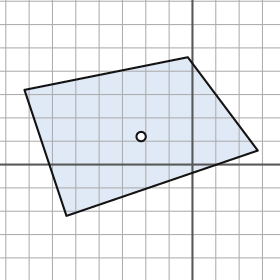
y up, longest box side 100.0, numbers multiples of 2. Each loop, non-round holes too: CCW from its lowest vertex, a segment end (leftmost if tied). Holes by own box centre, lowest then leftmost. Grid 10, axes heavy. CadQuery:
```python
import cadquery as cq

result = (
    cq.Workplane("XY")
    .moveTo(-54.0, -22.0)
    .lineTo(28.0, 6.0)
    .lineTo(-2.0, 46.0)
    .lineTo(-72.0, 32.0)
    .close()
    .moveTo(-22.0, 12.0)
    .circle(2.0)
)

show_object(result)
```